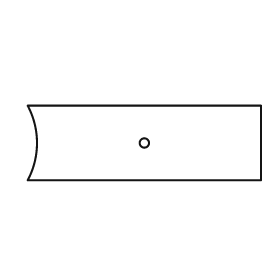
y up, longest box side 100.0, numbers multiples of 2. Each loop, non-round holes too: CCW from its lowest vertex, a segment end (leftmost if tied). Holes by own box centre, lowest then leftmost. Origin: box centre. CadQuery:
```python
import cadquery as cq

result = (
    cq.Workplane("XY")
    .moveTo(-50.0, -16.0)
    .lineTo(50.0, -16.0)
    .lineTo(50.0, 16.0)
    .lineTo(-50.0, 16.0)
    .threePointArc((-46.0, 0.0), (-50.0, -16.0))
    .close()
    .moveTo(0.0, 0.0)
    .circle(2.0)
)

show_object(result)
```